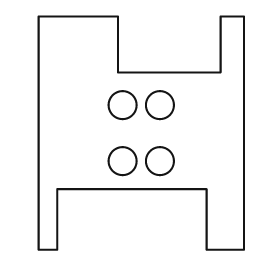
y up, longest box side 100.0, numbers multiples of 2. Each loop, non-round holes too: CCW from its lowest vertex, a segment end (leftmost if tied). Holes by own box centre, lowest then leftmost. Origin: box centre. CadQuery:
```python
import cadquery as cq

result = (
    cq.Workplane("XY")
    .moveTo(-44.0, -50.0)
    .lineTo(-36.0, -50.0)
    .lineTo(-36.0, -24.0)
    .lineTo(28.0, -24.0)
    .lineTo(28.0, -50.0)
    .lineTo(44.0, -50.0)
    .lineTo(44.0, 50.0)
    .lineTo(34.0, 50.0)
    .lineTo(34.0, 26.0)
    .lineTo(-10.0, 26.0)
    .lineTo(-10.0, 50.0)
    .lineTo(-44.0, 50.0)
    .close()
    .moveTo(-8.0, -12.0)
    .circle(6.0)
    .moveTo(8.0, -12.0)
    .circle(6.0)
    .moveTo(-8.0, 12.0)
    .circle(6.0)
    .moveTo(8.0, 12.0)
    .circle(6.0)
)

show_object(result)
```